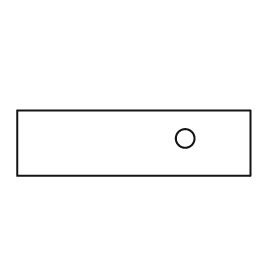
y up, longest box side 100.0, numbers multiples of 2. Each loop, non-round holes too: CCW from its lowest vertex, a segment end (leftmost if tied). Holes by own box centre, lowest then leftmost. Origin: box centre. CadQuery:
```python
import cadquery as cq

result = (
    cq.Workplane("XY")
    .moveTo(-50.0, -14.0)
    .lineTo(50.0, -14.0)
    .lineTo(50.0, 14.0)
    .lineTo(-50.0, 14.0)
    .close()
    .moveTo(22.0, 2.0)
    .circle(4.0)
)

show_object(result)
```